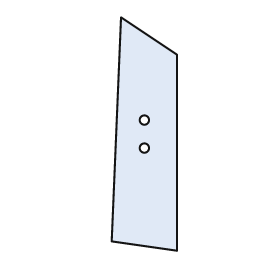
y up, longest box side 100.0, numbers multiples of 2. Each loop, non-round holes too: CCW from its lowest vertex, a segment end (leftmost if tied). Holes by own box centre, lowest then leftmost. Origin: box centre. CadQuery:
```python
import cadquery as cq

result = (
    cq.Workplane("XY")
    .moveTo(14.0, -50.0)
    .lineTo(14.0, 34.0)
    .lineTo(-10.0, 50.0)
    .lineTo(-14.0, -46.0)
    .close()
    .moveTo(0.0, -6.0)
    .circle(2.0)
    .moveTo(0.0, 6.0)
    .circle(2.0)
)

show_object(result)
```